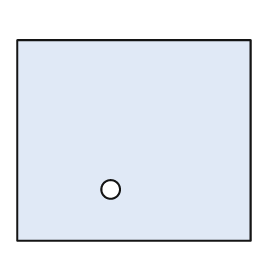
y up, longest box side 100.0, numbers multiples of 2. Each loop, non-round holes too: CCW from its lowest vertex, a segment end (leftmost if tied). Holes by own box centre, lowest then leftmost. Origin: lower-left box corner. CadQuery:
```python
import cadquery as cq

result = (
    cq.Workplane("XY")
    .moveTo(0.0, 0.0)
    .lineTo(100.0, 0.0)
    .lineTo(100.0, 86.0)
    .lineTo(0.0, 86.0)
    .close()
    .moveTo(40.0, 22.0)
    .circle(4.0)
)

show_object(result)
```